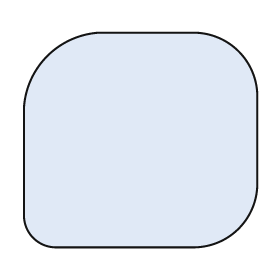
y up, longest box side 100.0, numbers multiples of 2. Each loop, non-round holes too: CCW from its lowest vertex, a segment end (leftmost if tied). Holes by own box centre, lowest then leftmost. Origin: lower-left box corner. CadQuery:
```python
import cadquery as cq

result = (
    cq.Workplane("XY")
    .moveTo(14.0, 0.0)
    .lineTo(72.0, 0.0)
    .threePointArc((92.0, 8.0), (100.0, 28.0))
    .lineTo(100.0, 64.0)
    .threePointArc((92.0, 84.0), (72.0, 92.0))
    .lineTo(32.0, 92.0)
    .threePointArc((10.0, 82.0), (0.0, 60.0))
    .lineTo(0.0, 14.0)
    .threePointArc((4.0, 4.0), (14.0, 0.0))
    .close()
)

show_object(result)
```